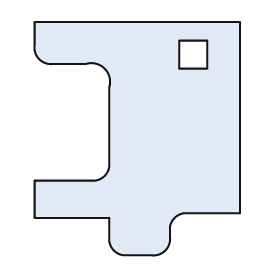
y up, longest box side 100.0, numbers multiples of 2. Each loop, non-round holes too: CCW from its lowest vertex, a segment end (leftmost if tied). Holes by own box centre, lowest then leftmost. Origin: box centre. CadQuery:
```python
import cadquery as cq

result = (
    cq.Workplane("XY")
    .moveTo(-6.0, -50.0)
    .lineTo(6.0, -50.0)
    .threePointArc((12.0, -48.0), (14.0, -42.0))
    .lineTo(14.0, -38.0)
    .threePointArc((16.0, -34.0), (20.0, -32.0))
    .lineTo(44.0, -32.0)
    .lineTo(44.0, 50.0)
    .lineTo(-44.0, 50.0)
    .lineTo(-44.0, 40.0)
    .threePointArc((-42.0, 34.0), (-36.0, 32.0))
    .lineTo(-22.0, 32.0)
    .threePointArc((-14.0, 30.0), (-12.0, 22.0))
    .lineTo(-12.0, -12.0)
    .threePointArc((-14.0, -16.0), (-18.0, -18.0))
    .lineTo(-44.0, -18.0)
    .lineTo(-44.0, -34.0)
    .lineTo(-12.0, -34.0)
    .lineTo(-12.0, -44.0)
    .threePointArc((-10.0, -48.0), (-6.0, -50.0))
    .close()
    .moveTo(18.0, 30.0)
    .lineTo(30.0, 30.0)
    .lineTo(30.0, 42.0)
    .lineTo(18.0, 42.0)
    .close()
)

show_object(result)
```